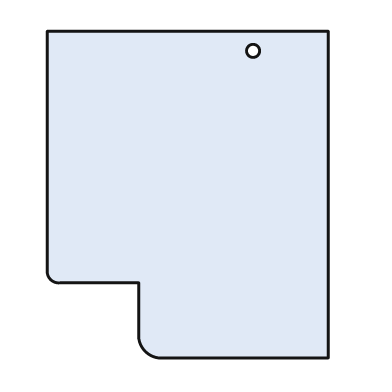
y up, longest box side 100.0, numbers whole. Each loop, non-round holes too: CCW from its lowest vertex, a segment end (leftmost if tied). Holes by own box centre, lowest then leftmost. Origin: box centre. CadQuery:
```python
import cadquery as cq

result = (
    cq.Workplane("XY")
    .moveTo(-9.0, -50.0)
    .lineTo(43.0, -50.0)
    .lineTo(43.0, 50.0)
    .lineTo(-43.0, 50.0)
    .lineTo(-43.0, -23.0)
    .threePointArc((-42.0, -26.0), (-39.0, -27.0))
    .lineTo(-15.0, -27.0)
    .lineTo(-15.0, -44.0)
    .threePointArc((-13.0, -48.0), (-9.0, -50.0))
    .close()
    .moveTo(20.0, 44.0)
    .circle(2.0)
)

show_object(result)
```